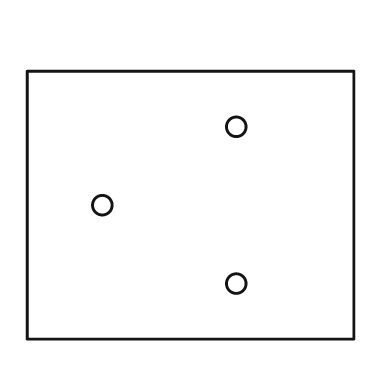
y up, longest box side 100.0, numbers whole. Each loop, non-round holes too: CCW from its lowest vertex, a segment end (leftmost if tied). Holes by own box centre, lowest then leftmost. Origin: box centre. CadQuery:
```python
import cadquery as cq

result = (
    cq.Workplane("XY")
    .moveTo(-50.0, -41.0)
    .lineTo(50.0, -41.0)
    .lineTo(50.0, 41.0)
    .lineTo(-50.0, 41.0)
    .close()
    .moveTo(14.0, -24.0)
    .circle(3.0)
    .moveTo(-27.0, 0.0)
    .circle(3.0)
    .moveTo(14.0, 24.0)
    .circle(3.0)
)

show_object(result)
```